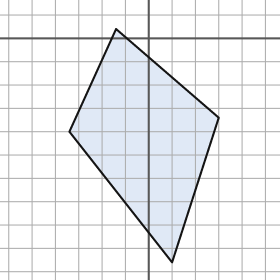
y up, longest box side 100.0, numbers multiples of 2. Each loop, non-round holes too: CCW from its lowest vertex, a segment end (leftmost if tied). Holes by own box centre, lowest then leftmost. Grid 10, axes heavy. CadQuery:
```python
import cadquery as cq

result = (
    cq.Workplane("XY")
    .moveTo(10.0, -96.0)
    .lineTo(30.0, -34.0)
    .lineTo(-14.0, 4.0)
    .lineTo(-34.0, -40.0)
    .close()
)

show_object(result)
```